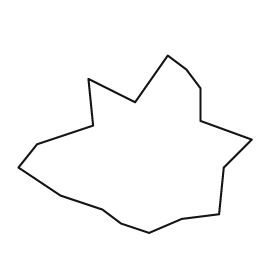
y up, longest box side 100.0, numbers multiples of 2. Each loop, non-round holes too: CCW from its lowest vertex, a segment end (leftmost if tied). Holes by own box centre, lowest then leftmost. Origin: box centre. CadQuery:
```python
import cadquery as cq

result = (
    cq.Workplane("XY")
    .moveTo(6.0, -38.0)
    .lineTo(20.0, -32.0)
    .lineTo(36.0, -30.0)
    .lineTo(38.0, -10.0)
    .lineTo(50.0, 2.0)
    .lineTo(28.0, 10.0)
    .lineTo(28.0, 24.0)
    .lineTo(22.0, 32.0)
    .lineTo(14.0, 38.0)
    .lineTo(0.0, 18.0)
    .lineTo(-20.0, 28.0)
    .lineTo(-18.0, 8.0)
    .lineTo(-42.0, 0.0)
    .lineTo(-50.0, -10.0)
    .lineTo(-32.0, -22.0)
    .lineTo(-14.0, -28.0)
    .lineTo(-6.0, -34.0)
    .close()
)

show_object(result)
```